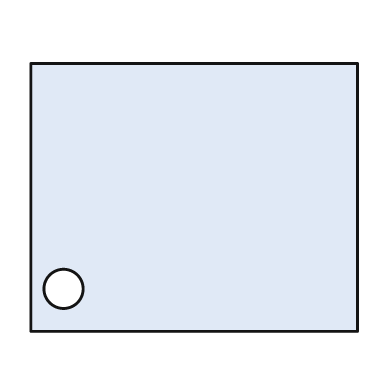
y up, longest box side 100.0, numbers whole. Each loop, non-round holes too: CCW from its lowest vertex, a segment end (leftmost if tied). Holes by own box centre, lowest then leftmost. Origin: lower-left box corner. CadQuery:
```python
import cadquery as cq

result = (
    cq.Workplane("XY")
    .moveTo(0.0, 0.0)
    .lineTo(100.0, 0.0)
    .lineTo(100.0, 82.0)
    .lineTo(0.0, 82.0)
    .close()
    .moveTo(10.0, 13.0)
    .circle(6.0)
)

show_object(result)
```